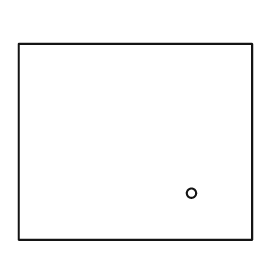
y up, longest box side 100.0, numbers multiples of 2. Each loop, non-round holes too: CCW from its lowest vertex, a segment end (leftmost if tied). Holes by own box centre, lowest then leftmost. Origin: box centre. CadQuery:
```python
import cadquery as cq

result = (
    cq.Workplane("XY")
    .moveTo(-50.0, -42.0)
    .lineTo(50.0, -42.0)
    .lineTo(50.0, 42.0)
    .lineTo(-50.0, 42.0)
    .close()
    .moveTo(24.0, -22.0)
    .circle(2.0)
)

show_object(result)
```